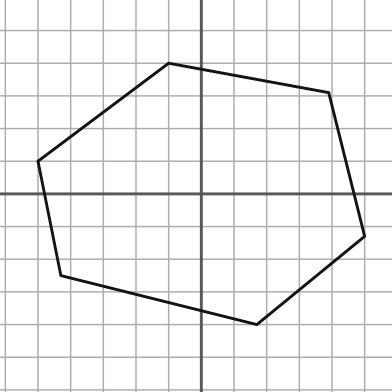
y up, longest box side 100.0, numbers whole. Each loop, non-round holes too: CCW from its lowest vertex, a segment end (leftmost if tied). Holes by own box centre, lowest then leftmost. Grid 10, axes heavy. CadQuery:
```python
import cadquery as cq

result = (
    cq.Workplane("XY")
    .moveTo(17.0, -40.0)
    .lineTo(50.0, -13.0)
    .lineTo(39.0, 31.0)
    .lineTo(-10.0, 40.0)
    .lineTo(-50.0, 10.0)
    .lineTo(-43.0, -25.0)
    .close()
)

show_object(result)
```